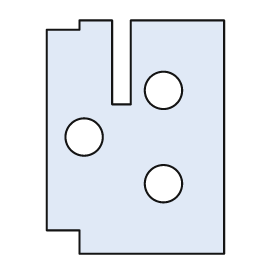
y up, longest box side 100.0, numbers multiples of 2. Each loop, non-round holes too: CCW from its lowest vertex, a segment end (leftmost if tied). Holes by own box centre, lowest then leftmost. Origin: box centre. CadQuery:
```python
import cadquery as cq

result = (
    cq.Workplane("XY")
    .moveTo(-24.0, -50.0)
    .lineTo(38.0, -50.0)
    .lineTo(38.0, 50.0)
    .lineTo(-2.0, 50.0)
    .lineTo(-2.0, 14.0)
    .lineTo(-10.0, 14.0)
    .lineTo(-10.0, 50.0)
    .lineTo(-24.0, 50.0)
    .lineTo(-24.0, 46.0)
    .lineTo(-38.0, 46.0)
    .lineTo(-38.0, -40.0)
    .lineTo(-24.0, -40.0)
    .close()
    .moveTo(12.0, -20.0)
    .circle(8.0)
    .moveTo(-22.0, 0.0)
    .circle(8.0)
    .moveTo(12.0, 20.0)
    .circle(8.0)
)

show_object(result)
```